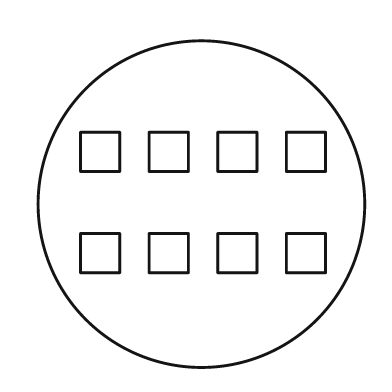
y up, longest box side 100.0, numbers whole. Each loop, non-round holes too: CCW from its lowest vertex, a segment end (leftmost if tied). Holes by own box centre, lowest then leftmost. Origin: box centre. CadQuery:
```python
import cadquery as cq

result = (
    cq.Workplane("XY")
    .moveTo(0.0, 0.0)
    .circle(50.0)
    .moveTo(-37.0, -21.0)
    .lineTo(-25.0, -21.0)
    .lineTo(-25.0, -9.0)
    .lineTo(-37.0, -9.0)
    .close()
    .moveTo(-16.0, -21.0)
    .lineTo(-4.0, -21.0)
    .lineTo(-4.0, -9.0)
    .lineTo(-16.0, -9.0)
    .close()
    .moveTo(5.0, -21.0)
    .lineTo(17.0, -21.0)
    .lineTo(17.0, -9.0)
    .lineTo(5.0, -9.0)
    .close()
    .moveTo(26.0, -21.0)
    .lineTo(38.0, -21.0)
    .lineTo(38.0, -9.0)
    .lineTo(26.0, -9.0)
    .close()
    .moveTo(-37.0, 10.0)
    .lineTo(-25.0, 10.0)
    .lineTo(-25.0, 22.0)
    .lineTo(-37.0, 22.0)
    .close()
    .moveTo(-16.0, 10.0)
    .lineTo(-4.0, 10.0)
    .lineTo(-4.0, 22.0)
    .lineTo(-16.0, 22.0)
    .close()
    .moveTo(5.0, 10.0)
    .lineTo(17.0, 10.0)
    .lineTo(17.0, 22.0)
    .lineTo(5.0, 22.0)
    .close()
    .moveTo(26.0, 10.0)
    .lineTo(38.0, 10.0)
    .lineTo(38.0, 22.0)
    .lineTo(26.0, 22.0)
    .close()
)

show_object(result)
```